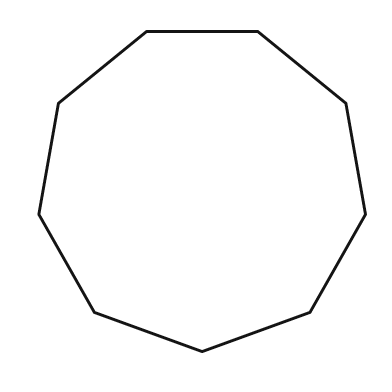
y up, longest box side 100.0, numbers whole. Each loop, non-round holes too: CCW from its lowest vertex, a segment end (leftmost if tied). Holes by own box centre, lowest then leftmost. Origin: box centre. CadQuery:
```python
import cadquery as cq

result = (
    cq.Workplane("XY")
    .moveTo(0.0, -49.0)
    .lineTo(33.0, -37.0)
    .lineTo(50.0, -7.0)
    .lineTo(44.0, 27.0)
    .lineTo(17.0, 49.0)
    .lineTo(-17.0, 49.0)
    .lineTo(-44.0, 27.0)
    .lineTo(-50.0, -7.0)
    .lineTo(-33.0, -37.0)
    .close()
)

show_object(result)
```